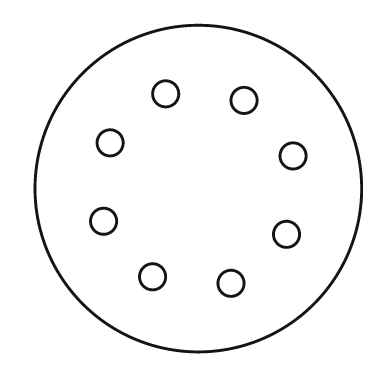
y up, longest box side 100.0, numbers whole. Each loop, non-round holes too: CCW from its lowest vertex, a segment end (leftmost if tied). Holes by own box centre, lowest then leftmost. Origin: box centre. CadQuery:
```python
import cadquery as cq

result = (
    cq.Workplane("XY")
    .moveTo(0.0, 0.0)
    .circle(50.0)
    .moveTo(10.0, -29.0)
    .circle(4.0)
    .moveTo(-14.0, -27.0)
    .circle(4.0)
    .moveTo(27.0, -14.0)
    .circle(4.0)
    .moveTo(-29.0, -10.0)
    .circle(4.0)
    .moveTo(29.0, 10.0)
    .circle(4.0)
    .moveTo(-27.0, 14.0)
    .circle(4.0)
    .moveTo(14.0, 27.0)
    .circle(4.0)
    .moveTo(-10.0, 29.0)
    .circle(4.0)
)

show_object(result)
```